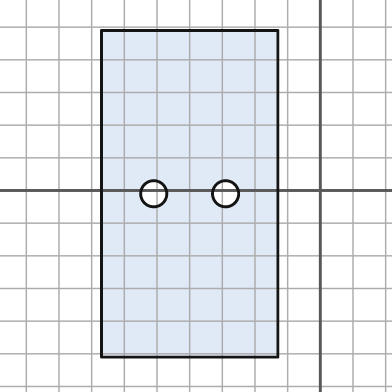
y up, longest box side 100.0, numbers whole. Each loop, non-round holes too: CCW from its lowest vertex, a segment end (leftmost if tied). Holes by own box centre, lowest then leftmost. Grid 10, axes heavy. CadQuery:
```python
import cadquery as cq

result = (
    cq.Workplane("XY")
    .moveTo(-67.0, -51.0)
    .lineTo(-13.0, -51.0)
    .lineTo(-13.0, 49.0)
    .lineTo(-67.0, 49.0)
    .close()
    .moveTo(-51.0, -1.0)
    .circle(4.0)
    .moveTo(-29.0, -1.0)
    .circle(4.0)
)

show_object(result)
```